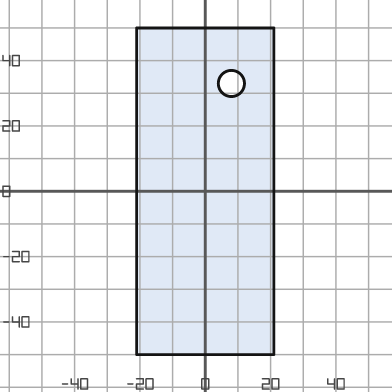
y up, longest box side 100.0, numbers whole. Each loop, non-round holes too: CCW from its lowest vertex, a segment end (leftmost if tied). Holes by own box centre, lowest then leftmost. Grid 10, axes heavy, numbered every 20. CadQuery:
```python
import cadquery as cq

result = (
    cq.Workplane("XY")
    .moveTo(-21.0, -50.0)
    .lineTo(21.0, -50.0)
    .lineTo(21.0, 50.0)
    .lineTo(-21.0, 50.0)
    .close()
    .moveTo(8.0, 33.0)
    .circle(4.0)
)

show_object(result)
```